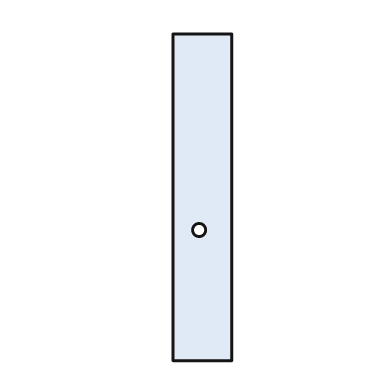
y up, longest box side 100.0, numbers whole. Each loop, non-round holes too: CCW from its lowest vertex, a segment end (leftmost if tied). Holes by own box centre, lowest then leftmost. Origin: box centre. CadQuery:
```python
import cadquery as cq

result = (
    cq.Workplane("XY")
    .moveTo(-9.0, -50.0)
    .lineTo(9.0, -50.0)
    .lineTo(9.0, 50.0)
    .lineTo(-9.0, 50.0)
    .close()
    .moveTo(-1.0, -10.0)
    .circle(2.0)
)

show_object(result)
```